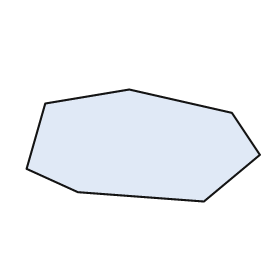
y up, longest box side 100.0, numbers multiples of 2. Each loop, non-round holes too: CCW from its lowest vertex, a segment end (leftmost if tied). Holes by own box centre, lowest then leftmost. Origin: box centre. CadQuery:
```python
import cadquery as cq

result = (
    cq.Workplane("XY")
    .moveTo(26.0, -24.0)
    .lineTo(50.0, -4.0)
    .lineTo(38.0, 14.0)
    .lineTo(-6.0, 24.0)
    .lineTo(-42.0, 18.0)
    .lineTo(-50.0, -10.0)
    .lineTo(-28.0, -20.0)
    .close()
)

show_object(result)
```